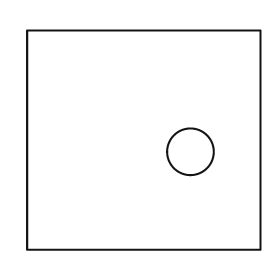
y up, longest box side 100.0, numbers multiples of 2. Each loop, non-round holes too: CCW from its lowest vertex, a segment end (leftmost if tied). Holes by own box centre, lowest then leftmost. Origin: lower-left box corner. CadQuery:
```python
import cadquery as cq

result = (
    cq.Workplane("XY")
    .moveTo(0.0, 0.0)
    .lineTo(100.0, 0.0)
    .lineTo(100.0, 94.0)
    .lineTo(0.0, 94.0)
    .close()
    .moveTo(70.0, 42.0)
    .circle(10.0)
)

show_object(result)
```